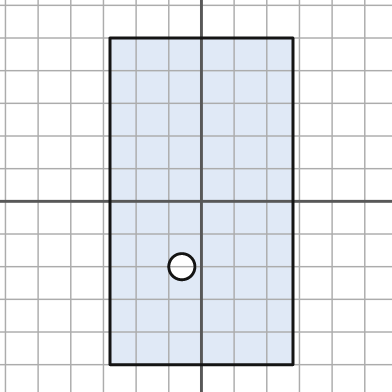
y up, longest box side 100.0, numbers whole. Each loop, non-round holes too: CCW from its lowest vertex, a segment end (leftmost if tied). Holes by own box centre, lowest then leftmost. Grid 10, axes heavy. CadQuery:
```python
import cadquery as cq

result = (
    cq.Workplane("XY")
    .moveTo(-28.0, -50.0)
    .lineTo(28.0, -50.0)
    .lineTo(28.0, 50.0)
    .lineTo(-28.0, 50.0)
    .close()
    .moveTo(-6.0, -20.0)
    .circle(4.0)
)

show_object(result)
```